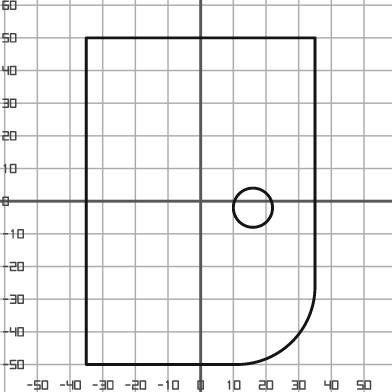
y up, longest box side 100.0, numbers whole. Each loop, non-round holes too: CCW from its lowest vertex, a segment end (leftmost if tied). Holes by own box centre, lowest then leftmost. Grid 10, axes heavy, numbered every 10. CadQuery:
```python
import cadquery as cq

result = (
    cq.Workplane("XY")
    .moveTo(-35.0, -50.0)
    .lineTo(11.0, -50.0)
    .threePointArc((28.0, -43.0), (35.0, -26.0))
    .lineTo(35.0, 50.0)
    .lineTo(-35.0, 50.0)
    .close()
    .moveTo(16.0, -2.0)
    .circle(6.0)
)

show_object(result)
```